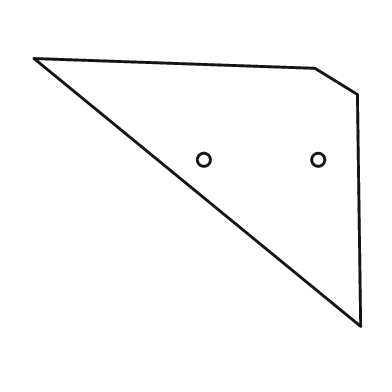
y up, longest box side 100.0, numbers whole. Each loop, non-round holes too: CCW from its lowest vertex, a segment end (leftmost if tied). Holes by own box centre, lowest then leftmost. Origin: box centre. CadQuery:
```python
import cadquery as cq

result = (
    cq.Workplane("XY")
    .moveTo(50.0, -41.0)
    .lineTo(49.0, 30.0)
    .lineTo(36.0, 38.0)
    .lineTo(-50.0, 41.0)
    .close()
    .moveTo(2.0, 10.0)
    .circle(2.0)
    .moveTo(37.0, 10.0)
    .circle(2.0)
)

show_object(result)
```